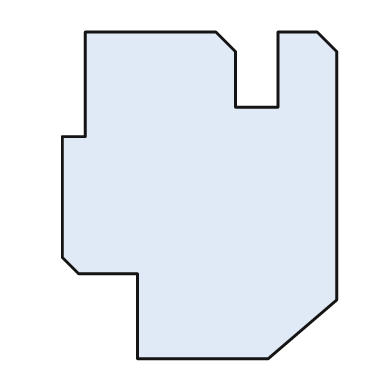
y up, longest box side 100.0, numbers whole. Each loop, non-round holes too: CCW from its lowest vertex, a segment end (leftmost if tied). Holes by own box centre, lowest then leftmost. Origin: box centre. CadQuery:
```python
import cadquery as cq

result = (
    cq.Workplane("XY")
    .moveTo(-19.0, -50.0)
    .lineTo(21.0, -50.0)
    .lineTo(42.0, -32.0)
    .lineTo(42.0, 44.0)
    .lineTo(36.0, 50.0)
    .lineTo(24.0, 50.0)
    .lineTo(24.0, 27.0)
    .lineTo(11.0, 27.0)
    .lineTo(11.0, 44.0)
    .lineTo(5.0, 50.0)
    .lineTo(-35.0, 50.0)
    .lineTo(-35.0, 18.0)
    .lineTo(-42.0, 18.0)
    .lineTo(-42.0, -19.0)
    .lineTo(-37.0, -24.0)
    .lineTo(-19.0, -24.0)
    .close()
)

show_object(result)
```